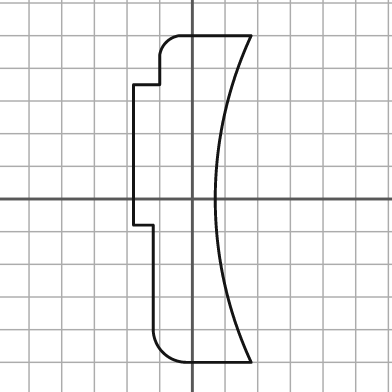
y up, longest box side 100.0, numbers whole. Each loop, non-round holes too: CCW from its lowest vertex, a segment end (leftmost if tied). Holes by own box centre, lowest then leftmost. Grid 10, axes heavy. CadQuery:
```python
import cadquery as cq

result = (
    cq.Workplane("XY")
    .moveTo(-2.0, -50.0)
    .lineTo(18.0, -50.0)
    .threePointArc((7.0, 0.0), (18.0, 50.0))
    .lineTo(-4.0, 50.0)
    .threePointArc((-8.0, 48.0), (-10.0, 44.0))
    .lineTo(-10.0, 35.0)
    .lineTo(-18.0, 35.0)
    .lineTo(-18.0, -8.0)
    .lineTo(-12.0, -8.0)
    .lineTo(-12.0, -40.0)
    .threePointArc((-9.0, -47.0), (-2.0, -50.0))
    .close()
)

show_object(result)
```